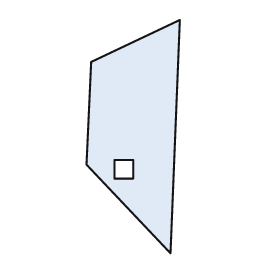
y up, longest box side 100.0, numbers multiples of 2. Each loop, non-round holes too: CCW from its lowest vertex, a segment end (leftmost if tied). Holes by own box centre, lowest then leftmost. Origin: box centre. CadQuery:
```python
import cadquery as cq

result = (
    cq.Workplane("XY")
    .moveTo(16.0, -50.0)
    .lineTo(20.0, 50.0)
    .lineTo(-18.0, 32.0)
    .lineTo(-20.0, -12.0)
    .close()
    .moveTo(-8.0, -18.0)
    .lineTo(0.0, -18.0)
    .lineTo(0.0, -10.0)
    .lineTo(-8.0, -10.0)
    .close()
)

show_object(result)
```